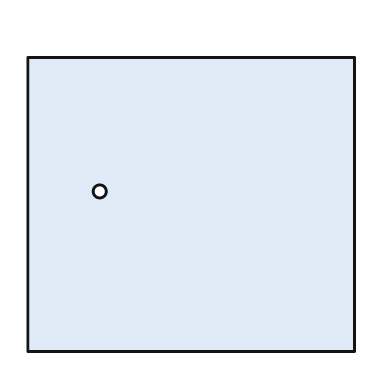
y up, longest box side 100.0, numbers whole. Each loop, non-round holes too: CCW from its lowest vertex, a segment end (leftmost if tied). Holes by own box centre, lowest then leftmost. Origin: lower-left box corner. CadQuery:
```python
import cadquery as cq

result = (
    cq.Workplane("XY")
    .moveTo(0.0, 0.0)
    .lineTo(100.0, 0.0)
    .lineTo(100.0, 90.0)
    .lineTo(0.0, 90.0)
    .close()
    .moveTo(22.0, 49.0)
    .circle(2.0)
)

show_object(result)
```